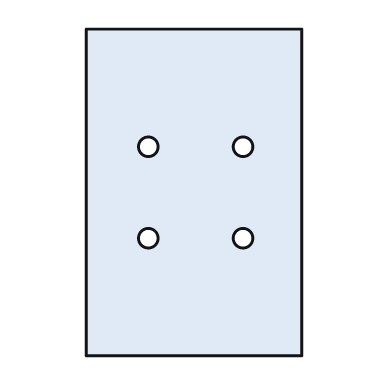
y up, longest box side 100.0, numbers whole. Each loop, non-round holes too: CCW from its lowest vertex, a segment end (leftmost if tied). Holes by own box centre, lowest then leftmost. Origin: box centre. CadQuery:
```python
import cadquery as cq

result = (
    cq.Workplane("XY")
    .moveTo(-33.0, -50.0)
    .lineTo(33.0, -50.0)
    .lineTo(33.0, 50.0)
    .lineTo(-33.0, 50.0)
    .close()
    .moveTo(-14.0, -14.0)
    .circle(3.0)
    .moveTo(15.0, -14.0)
    .circle(3.0)
    .moveTo(-14.0, 14.0)
    .circle(3.0)
    .moveTo(15.0, 14.0)
    .circle(3.0)
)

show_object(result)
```